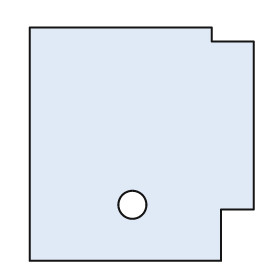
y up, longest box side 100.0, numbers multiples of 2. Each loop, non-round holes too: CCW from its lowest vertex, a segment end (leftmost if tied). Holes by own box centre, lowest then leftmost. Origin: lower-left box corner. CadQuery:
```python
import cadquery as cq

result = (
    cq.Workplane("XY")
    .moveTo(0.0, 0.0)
    .lineTo(82.0, 0.0)
    .lineTo(82.0, 22.0)
    .lineTo(96.0, 22.0)
    .lineTo(96.0, 94.0)
    .lineTo(78.0, 94.0)
    .lineTo(78.0, 100.0)
    .lineTo(0.0, 100.0)
    .close()
    .moveTo(44.0, 24.0)
    .circle(6.0)
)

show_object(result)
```